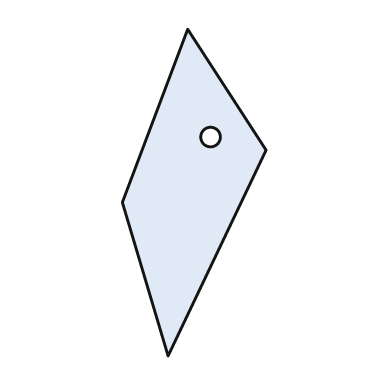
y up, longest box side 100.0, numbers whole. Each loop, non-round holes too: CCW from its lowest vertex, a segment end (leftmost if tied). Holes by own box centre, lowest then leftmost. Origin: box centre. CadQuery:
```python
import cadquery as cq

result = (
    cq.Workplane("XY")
    .moveTo(-8.0, -50.0)
    .lineTo(22.0, 13.0)
    .lineTo(-2.0, 50.0)
    .lineTo(-22.0, -3.0)
    .close()
    .moveTo(5.0, 17.0)
    .circle(3.0)
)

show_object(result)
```